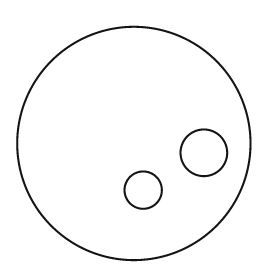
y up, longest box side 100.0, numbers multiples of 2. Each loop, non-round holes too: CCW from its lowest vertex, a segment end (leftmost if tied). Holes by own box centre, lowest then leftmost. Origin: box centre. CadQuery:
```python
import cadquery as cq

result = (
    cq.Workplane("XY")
    .moveTo(0.0, 0.0)
    .circle(50.0)
    .moveTo(4.0, -20.0)
    .circle(8.0)
    .moveTo(30.0, -4.0)
    .circle(10.0)
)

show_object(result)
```